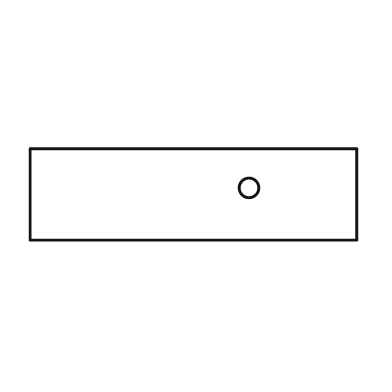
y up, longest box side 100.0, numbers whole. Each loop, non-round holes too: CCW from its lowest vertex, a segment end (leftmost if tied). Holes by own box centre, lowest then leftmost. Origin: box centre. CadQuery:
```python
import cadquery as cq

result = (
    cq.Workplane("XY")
    .moveTo(-50.0, -14.0)
    .lineTo(50.0, -14.0)
    .lineTo(50.0, 14.0)
    .lineTo(-50.0, 14.0)
    .close()
    .moveTo(17.0, 2.0)
    .circle(3.0)
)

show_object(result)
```